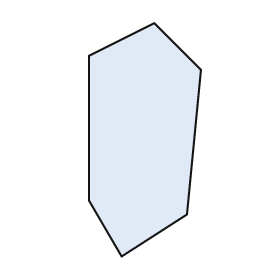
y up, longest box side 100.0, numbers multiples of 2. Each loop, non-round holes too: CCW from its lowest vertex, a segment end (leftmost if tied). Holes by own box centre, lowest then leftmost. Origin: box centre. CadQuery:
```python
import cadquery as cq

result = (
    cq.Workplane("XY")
    .moveTo(-10.0, -50.0)
    .lineTo(18.0, -32.0)
    .lineTo(24.0, 30.0)
    .lineTo(4.0, 50.0)
    .lineTo(-24.0, 36.0)
    .lineTo(-24.0, -26.0)
    .close()
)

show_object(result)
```